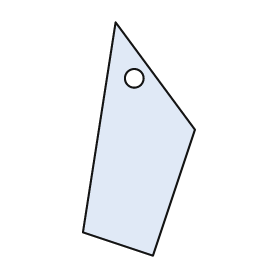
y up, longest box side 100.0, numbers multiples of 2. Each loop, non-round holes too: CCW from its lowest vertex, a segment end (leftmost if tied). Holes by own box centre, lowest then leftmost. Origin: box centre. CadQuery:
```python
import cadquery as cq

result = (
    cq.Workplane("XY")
    .moveTo(6.0, -50.0)
    .lineTo(24.0, 4.0)
    .lineTo(-10.0, 50.0)
    .lineTo(-24.0, -40.0)
    .close()
    .moveTo(-2.0, 26.0)
    .circle(4.0)
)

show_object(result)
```